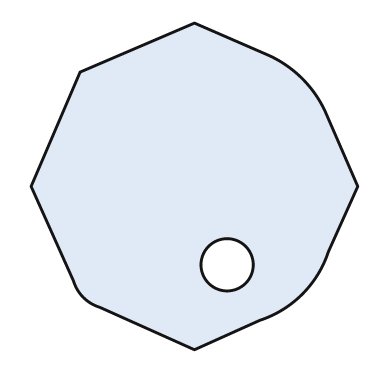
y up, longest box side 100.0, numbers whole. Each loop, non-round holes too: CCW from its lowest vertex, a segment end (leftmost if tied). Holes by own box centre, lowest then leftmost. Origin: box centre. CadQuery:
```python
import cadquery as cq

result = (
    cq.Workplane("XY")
    .moveTo(0.0, -50.0)
    .lineTo(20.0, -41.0)
    .threePointArc((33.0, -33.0), (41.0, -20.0))
    .lineTo(50.0, 0.0)
    .lineTo(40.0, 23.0)
    .threePointArc((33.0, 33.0), (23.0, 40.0))
    .lineTo(0.0, 50.0)
    .lineTo(-35.0, 35.0)
    .lineTo(-50.0, 0.0)
    .lineTo(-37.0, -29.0)
    .threePointArc((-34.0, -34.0), (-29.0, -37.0))
    .close()
    .moveTo(10.0, -24.0)
    .circle(8.0)
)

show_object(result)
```